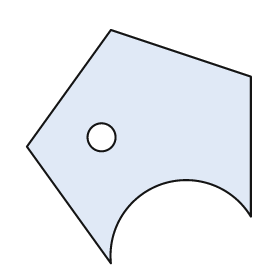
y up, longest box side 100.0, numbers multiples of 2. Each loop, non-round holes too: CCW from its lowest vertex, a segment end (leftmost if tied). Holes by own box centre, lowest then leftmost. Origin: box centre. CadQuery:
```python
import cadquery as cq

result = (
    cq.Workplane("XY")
    .moveTo(-12.0, -50.0)
    .threePointArc((10.0, -16.0), (48.0, -30.0))
    .lineTo(48.0, 30.0)
    .lineTo(-12.0, 50.0)
    .lineTo(-48.0, 0.0)
    .close()
    .moveTo(-16.0, 4.0)
    .circle(6.0)
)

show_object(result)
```